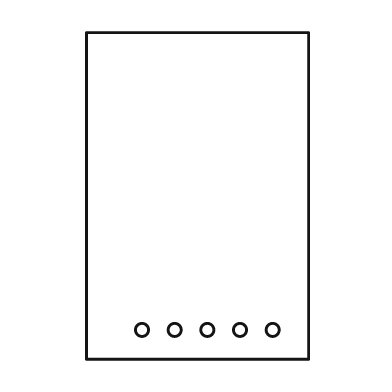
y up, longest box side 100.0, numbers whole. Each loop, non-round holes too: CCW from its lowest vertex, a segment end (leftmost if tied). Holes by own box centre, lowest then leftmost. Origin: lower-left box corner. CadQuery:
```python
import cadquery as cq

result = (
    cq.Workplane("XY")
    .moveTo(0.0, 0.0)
    .lineTo(68.0, 0.0)
    .lineTo(68.0, 100.0)
    .lineTo(0.0, 100.0)
    .close()
    .moveTo(17.0, 9.0)
    .circle(2.0)
    .moveTo(27.0, 9.0)
    .circle(2.0)
    .moveTo(37.0, 9.0)
    .circle(2.0)
    .moveTo(47.0, 9.0)
    .circle(2.0)
    .moveTo(57.0, 9.0)
    .circle(2.0)
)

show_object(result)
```